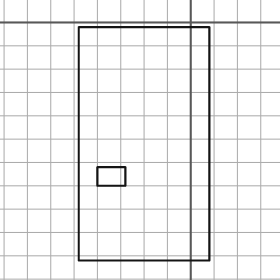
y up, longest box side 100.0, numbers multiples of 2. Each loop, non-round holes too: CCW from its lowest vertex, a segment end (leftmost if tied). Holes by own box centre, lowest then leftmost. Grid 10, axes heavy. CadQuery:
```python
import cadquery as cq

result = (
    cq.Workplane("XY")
    .moveTo(-48.0, -102.0)
    .lineTo(8.0, -102.0)
    .lineTo(8.0, -2.0)
    .lineTo(-48.0, -2.0)
    .close()
    .moveTo(-40.0, -70.0)
    .lineTo(-28.0, -70.0)
    .lineTo(-28.0, -62.0)
    .lineTo(-40.0, -62.0)
    .close()
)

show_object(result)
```